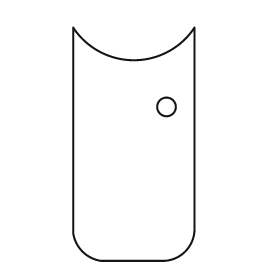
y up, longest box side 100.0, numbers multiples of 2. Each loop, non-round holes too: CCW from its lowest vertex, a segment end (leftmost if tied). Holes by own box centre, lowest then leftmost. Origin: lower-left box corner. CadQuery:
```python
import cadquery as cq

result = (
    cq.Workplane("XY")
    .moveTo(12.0, 0.0)
    .lineTo(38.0, 0.0)
    .threePointArc((48.0, 4.0), (52.0, 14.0))
    .lineTo(52.0, 100.0)
    .threePointArc((26.0, 86.0), (0.0, 100.0))
    .lineTo(0.0, 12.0)
    .threePointArc((4.0, 4.0), (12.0, 0.0))
    .close()
    .moveTo(40.0, 66.0)
    .circle(4.0)
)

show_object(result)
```